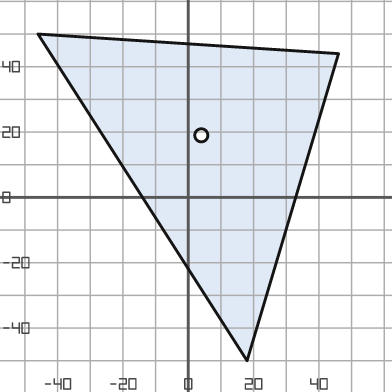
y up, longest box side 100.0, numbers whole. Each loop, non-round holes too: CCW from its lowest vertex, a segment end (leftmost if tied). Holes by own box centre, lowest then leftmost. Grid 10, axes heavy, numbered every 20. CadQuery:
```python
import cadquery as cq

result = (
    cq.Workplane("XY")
    .moveTo(18.0, -50.0)
    .lineTo(46.0, 44.0)
    .lineTo(-46.0, 50.0)
    .close()
    .moveTo(4.0, 19.0)
    .circle(2.0)
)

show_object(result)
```